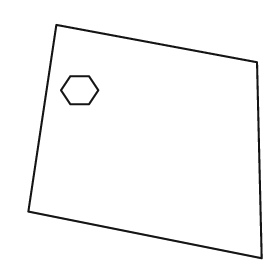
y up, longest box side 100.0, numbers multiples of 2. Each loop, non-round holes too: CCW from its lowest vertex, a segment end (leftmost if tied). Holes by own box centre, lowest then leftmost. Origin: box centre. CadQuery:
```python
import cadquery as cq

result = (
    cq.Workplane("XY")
    .moveTo(50.0, -50.0)
    .lineTo(48.0, 34.0)
    .lineTo(-38.0, 50.0)
    .lineTo(-50.0, -30.0)
    .close()
    .moveTo(-32.0, 16.0)
    .lineTo(-24.0, 16.0)
    .lineTo(-20.0, 22.0)
    .lineTo(-24.0, 28.0)
    .lineTo(-32.0, 28.0)
    .lineTo(-36.0, 22.0)
    .close()
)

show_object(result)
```